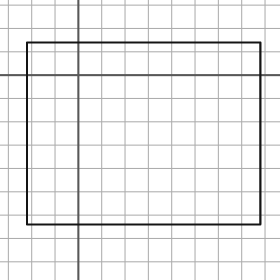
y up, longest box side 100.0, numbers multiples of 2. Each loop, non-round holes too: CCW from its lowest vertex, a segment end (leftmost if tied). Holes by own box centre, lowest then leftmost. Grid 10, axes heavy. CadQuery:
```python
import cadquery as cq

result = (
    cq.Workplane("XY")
    .moveTo(-22.0, -64.0)
    .lineTo(78.0, -64.0)
    .lineTo(78.0, 14.0)
    .lineTo(-22.0, 14.0)
    .close()
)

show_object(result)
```